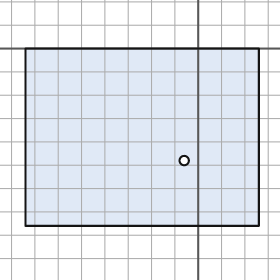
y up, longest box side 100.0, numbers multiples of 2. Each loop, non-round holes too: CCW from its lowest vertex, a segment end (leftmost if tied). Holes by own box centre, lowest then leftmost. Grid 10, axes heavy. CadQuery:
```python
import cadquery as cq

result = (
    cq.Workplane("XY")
    .moveTo(-74.0, -76.0)
    .lineTo(26.0, -76.0)
    .lineTo(26.0, 0.0)
    .lineTo(-74.0, 0.0)
    .close()
    .moveTo(-6.0, -48.0)
    .circle(2.0)
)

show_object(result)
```